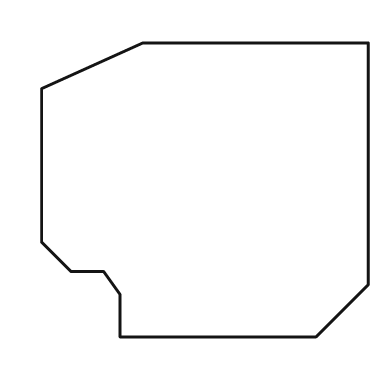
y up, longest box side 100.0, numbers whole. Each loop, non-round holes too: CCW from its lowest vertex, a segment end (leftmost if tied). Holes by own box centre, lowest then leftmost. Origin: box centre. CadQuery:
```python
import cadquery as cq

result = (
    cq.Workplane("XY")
    .moveTo(-26.0, -45.0)
    .lineTo(34.0, -45.0)
    .lineTo(50.0, -29.0)
    .lineTo(50.0, 45.0)
    .lineTo(-19.0, 45.0)
    .lineTo(-50.0, 31.0)
    .lineTo(-50.0, -16.0)
    .lineTo(-41.0, -25.0)
    .lineTo(-31.0, -25.0)
    .lineTo(-26.0, -32.0)
    .close()
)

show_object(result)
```